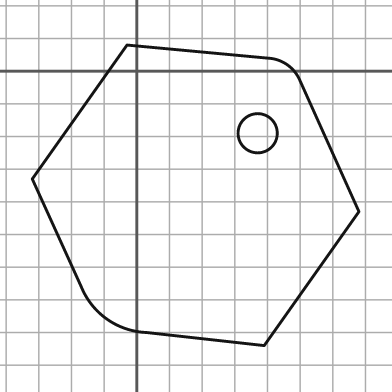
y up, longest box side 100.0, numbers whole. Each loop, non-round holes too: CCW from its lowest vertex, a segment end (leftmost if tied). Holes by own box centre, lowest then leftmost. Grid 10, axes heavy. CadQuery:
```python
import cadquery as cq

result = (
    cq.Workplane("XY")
    .moveTo(39.0, -84.0)
    .lineTo(68.0, -43.0)
    .lineTo(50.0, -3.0)
    .threePointArc((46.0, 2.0), (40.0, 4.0))
    .lineTo(-3.0, 8.0)
    .lineTo(-32.0, -33.0)
    .lineTo(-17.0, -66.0)
    .threePointArc((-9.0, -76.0), (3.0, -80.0))
    .close()
    .moveTo(37.0, -19.0)
    .circle(6.0)
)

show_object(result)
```